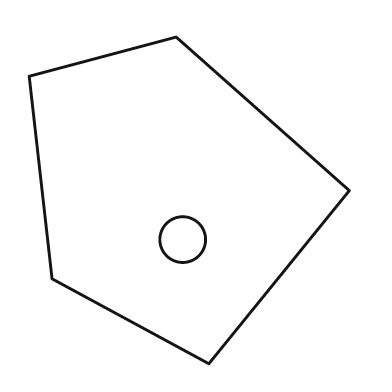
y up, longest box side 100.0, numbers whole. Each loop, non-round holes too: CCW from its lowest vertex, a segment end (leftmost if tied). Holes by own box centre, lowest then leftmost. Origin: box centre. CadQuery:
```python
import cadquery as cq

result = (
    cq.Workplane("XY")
    .moveTo(6.0, -50.0)
    .lineTo(49.0, 3.0)
    .lineTo(-4.0, 50.0)
    .lineTo(-49.0, 38.0)
    .lineTo(-42.0, -24.0)
    .close()
    .moveTo(-2.0, -12.0)
    .circle(7.0)
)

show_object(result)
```